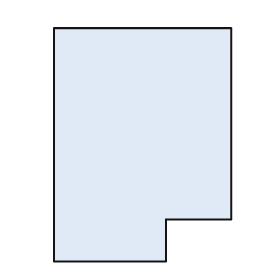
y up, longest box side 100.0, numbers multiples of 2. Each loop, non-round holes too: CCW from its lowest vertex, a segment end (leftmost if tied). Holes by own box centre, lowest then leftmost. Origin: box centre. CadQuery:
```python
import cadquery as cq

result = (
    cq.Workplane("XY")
    .moveTo(-38.0, -50.0)
    .lineTo(10.0, -50.0)
    .lineTo(10.0, -32.0)
    .lineTo(38.0, -32.0)
    .lineTo(38.0, 50.0)
    .lineTo(-38.0, 50.0)
    .close()
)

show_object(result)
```